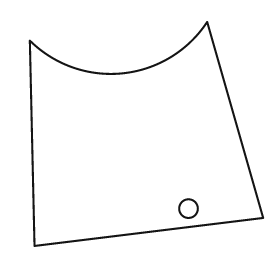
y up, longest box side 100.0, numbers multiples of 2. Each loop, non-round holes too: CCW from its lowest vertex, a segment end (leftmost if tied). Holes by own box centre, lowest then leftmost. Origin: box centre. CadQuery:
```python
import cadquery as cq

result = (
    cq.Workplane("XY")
    .moveTo(-48.0, -48.0)
    .lineTo(50.0, -36.0)
    .lineTo(26.0, 48.0)
    .threePointArc((-10.0, 26.0), (-50.0, 40.0))
    .close()
    .moveTo(18.0, -32.0)
    .circle(4.0)
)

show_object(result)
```